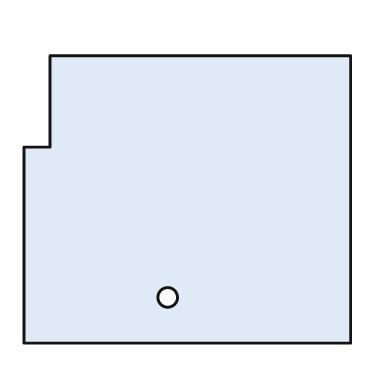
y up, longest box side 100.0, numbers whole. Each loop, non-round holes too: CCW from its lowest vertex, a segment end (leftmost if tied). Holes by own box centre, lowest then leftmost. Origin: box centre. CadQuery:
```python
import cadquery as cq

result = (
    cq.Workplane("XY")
    .moveTo(-50.0, -44.0)
    .lineTo(50.0, -44.0)
    .lineTo(50.0, 44.0)
    .lineTo(-42.0, 44.0)
    .lineTo(-42.0, 16.0)
    .lineTo(-50.0, 16.0)
    .close()
    .moveTo(-6.0, -30.0)
    .circle(3.0)
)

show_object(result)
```